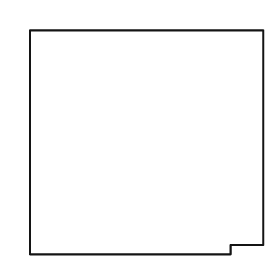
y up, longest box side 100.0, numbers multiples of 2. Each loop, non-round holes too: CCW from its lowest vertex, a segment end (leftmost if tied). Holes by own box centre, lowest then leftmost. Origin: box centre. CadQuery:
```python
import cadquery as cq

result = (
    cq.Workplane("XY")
    .moveTo(-50.0, -48.0)
    .lineTo(36.0, -48.0)
    .lineTo(36.0, -44.0)
    .lineTo(50.0, -44.0)
    .lineTo(50.0, 48.0)
    .lineTo(-50.0, 48.0)
    .close()
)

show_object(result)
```